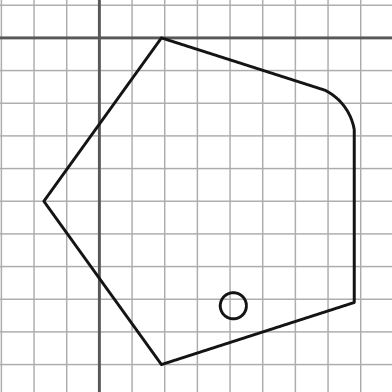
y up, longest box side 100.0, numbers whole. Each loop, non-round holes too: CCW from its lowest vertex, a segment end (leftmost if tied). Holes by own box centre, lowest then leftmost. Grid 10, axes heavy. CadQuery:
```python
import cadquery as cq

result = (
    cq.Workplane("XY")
    .moveTo(19.0, -100.0)
    .lineTo(78.0, -81.0)
    .lineTo(78.0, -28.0)
    .threePointArc((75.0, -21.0), (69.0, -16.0))
    .lineTo(19.0, 0.0)
    .lineTo(-17.0, -50.0)
    .close()
    .moveTo(41.0, -82.0)
    .circle(4.0)
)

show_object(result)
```